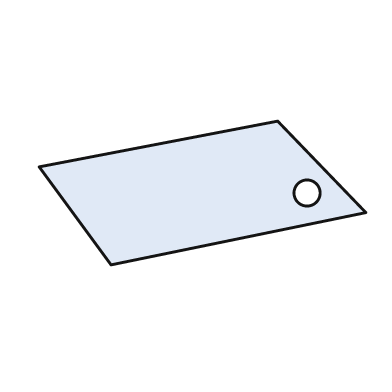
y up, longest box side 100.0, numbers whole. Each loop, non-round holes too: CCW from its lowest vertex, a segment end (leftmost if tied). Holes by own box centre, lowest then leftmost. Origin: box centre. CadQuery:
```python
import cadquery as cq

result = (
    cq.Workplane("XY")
    .moveTo(-28.0, -22.0)
    .lineTo(50.0, -6.0)
    .lineTo(23.0, 22.0)
    .lineTo(-50.0, 8.0)
    .close()
    .moveTo(32.0, 0.0)
    .circle(4.0)
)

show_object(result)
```